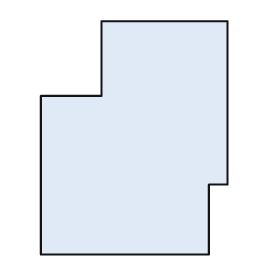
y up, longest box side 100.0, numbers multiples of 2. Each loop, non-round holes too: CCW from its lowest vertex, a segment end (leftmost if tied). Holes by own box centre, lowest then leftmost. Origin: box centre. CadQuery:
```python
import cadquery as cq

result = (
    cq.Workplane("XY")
    .moveTo(-40.0, -50.0)
    .lineTo(32.0, -50.0)
    .lineTo(32.0, -20.0)
    .lineTo(40.0, -20.0)
    .lineTo(40.0, 50.0)
    .lineTo(-14.0, 50.0)
    .lineTo(-14.0, 18.0)
    .lineTo(-40.0, 18.0)
    .close()
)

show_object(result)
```